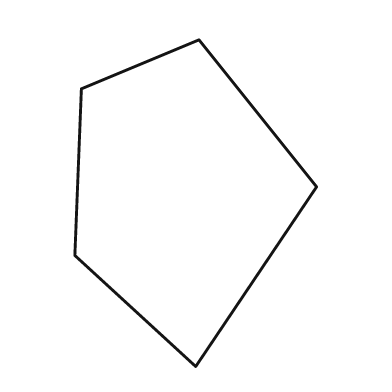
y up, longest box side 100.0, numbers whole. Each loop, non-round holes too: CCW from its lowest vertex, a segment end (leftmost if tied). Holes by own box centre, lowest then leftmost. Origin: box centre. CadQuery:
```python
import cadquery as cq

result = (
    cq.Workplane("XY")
    .moveTo(0.0, -50.0)
    .lineTo(37.0, 5.0)
    .lineTo(1.0, 50.0)
    .lineTo(-35.0, 35.0)
    .lineTo(-37.0, -16.0)
    .close()
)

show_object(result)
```